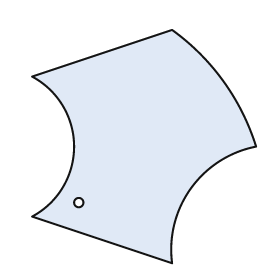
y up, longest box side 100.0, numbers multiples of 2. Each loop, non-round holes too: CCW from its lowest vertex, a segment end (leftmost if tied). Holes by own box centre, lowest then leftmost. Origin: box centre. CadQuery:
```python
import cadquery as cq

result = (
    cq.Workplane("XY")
    .moveTo(12.0, -50.0)
    .threePointArc((20.0, -18.0), (48.0, 0.0))
    .threePointArc((34.0, 28.0), (12.0, 50.0))
    .lineTo(-48.0, 30.0)
    .threePointArc((-30.0, 0.0), (-48.0, -30.0))
    .close()
    .moveTo(-28.0, -24.0)
    .circle(2.0)
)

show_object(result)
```